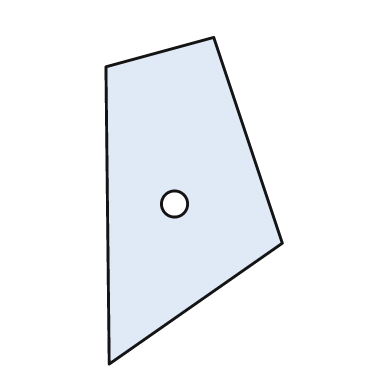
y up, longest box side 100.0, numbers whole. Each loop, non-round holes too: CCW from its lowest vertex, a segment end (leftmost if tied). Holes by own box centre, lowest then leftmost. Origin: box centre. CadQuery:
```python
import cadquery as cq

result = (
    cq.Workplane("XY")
    .moveTo(-26.0, -50.0)
    .lineTo(27.0, -13.0)
    .lineTo(6.0, 50.0)
    .lineTo(-27.0, 41.0)
    .close()
    .moveTo(-6.0, -1.0)
    .circle(4.0)
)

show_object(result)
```